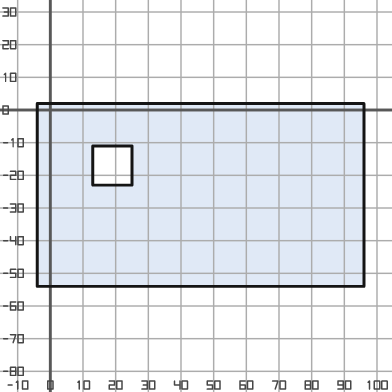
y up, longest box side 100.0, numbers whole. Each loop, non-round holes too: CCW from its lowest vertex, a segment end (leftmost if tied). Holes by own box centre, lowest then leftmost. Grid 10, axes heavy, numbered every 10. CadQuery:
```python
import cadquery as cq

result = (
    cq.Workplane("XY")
    .moveTo(-4.0, -54.0)
    .lineTo(96.0, -54.0)
    .lineTo(96.0, 2.0)
    .lineTo(-4.0, 2.0)
    .close()
    .moveTo(13.0, -23.0)
    .lineTo(25.0, -23.0)
    .lineTo(25.0, -11.0)
    .lineTo(13.0, -11.0)
    .close()
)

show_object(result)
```